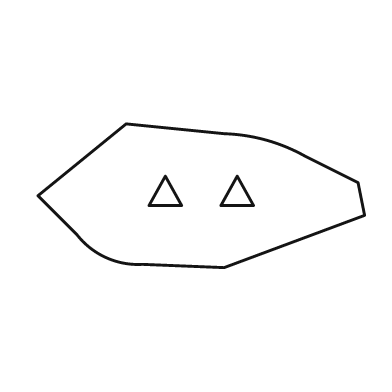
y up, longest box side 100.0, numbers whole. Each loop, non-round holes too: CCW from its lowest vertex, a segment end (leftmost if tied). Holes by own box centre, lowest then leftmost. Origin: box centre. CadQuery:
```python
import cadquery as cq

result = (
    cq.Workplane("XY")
    .moveTo(7.0, -22.0)
    .lineTo(50.0, -6.0)
    .lineTo(48.0, 4.0)
    .lineTo(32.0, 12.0)
    .threePointArc((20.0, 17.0), (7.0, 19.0))
    .lineTo(-23.0, 22.0)
    .lineTo(-50.0, 0.0)
    .lineTo(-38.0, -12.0)
    .threePointArc((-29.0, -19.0), (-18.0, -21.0))
    .close()
    .moveTo(-16.0, -3.0)
    .lineTo(-6.0, -3.0)
    .lineTo(-11.0, 6.0)
    .close()
    .moveTo(6.0, -3.0)
    .lineTo(16.0, -3.0)
    .lineTo(11.0, 6.0)
    .close()
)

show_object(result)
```